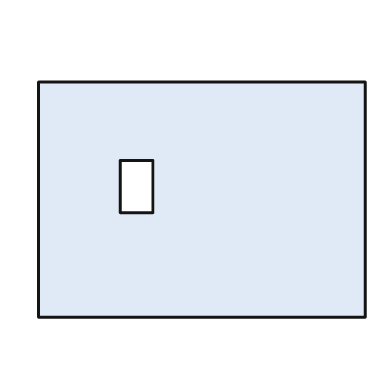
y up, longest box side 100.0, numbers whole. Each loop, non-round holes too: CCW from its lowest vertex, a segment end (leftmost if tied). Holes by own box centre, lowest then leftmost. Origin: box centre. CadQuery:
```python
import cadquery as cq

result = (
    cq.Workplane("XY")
    .moveTo(-50.0, -36.0)
    .lineTo(50.0, -36.0)
    .lineTo(50.0, 36.0)
    .lineTo(-50.0, 36.0)
    .close()
    .moveTo(-25.0, -4.0)
    .lineTo(-15.0, -4.0)
    .lineTo(-15.0, 12.0)
    .lineTo(-25.0, 12.0)
    .close()
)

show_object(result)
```